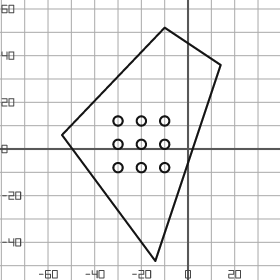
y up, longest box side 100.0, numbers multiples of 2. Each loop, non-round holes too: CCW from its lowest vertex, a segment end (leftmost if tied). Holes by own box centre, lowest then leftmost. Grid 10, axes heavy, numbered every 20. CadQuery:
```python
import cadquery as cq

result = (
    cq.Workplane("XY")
    .moveTo(-14.0, -48.0)
    .lineTo(14.0, 36.0)
    .lineTo(-10.0, 52.0)
    .lineTo(-54.0, 6.0)
    .close()
    .moveTo(-30.0, -8.0)
    .circle(2.0)
    .moveTo(-20.0, -8.0)
    .circle(2.0)
    .moveTo(-10.0, -8.0)
    .circle(2.0)
    .moveTo(-30.0, 2.0)
    .circle(2.0)
    .moveTo(-20.0, 2.0)
    .circle(2.0)
    .moveTo(-10.0, 2.0)
    .circle(2.0)
    .moveTo(-30.0, 12.0)
    .circle(2.0)
    .moveTo(-20.0, 12.0)
    .circle(2.0)
    .moveTo(-10.0, 12.0)
    .circle(2.0)
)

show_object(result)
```